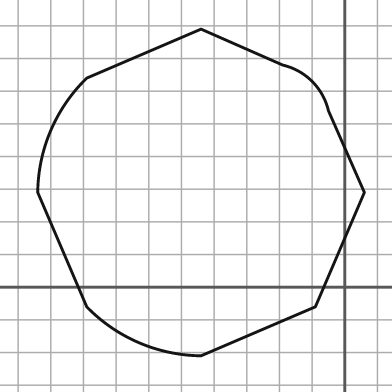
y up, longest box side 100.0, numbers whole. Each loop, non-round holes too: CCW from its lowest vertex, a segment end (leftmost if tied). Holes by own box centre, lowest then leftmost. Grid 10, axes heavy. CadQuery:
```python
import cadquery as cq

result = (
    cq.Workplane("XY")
    .moveTo(-44.0, -21.0)
    .lineTo(-9.0, -6.0)
    .lineTo(6.0, 29.0)
    .lineTo(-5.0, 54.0)
    .threePointArc((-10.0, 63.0), (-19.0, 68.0))
    .lineTo(-44.0, 79.0)
    .lineTo(-79.0, 64.0)
    .threePointArc((-90.0, 48.0), (-94.0, 29.0))
    .lineTo(-79.0, -6.0)
    .threePointArc((-63.0, -17.0), (-44.0, -21.0))
    .close()
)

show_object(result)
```